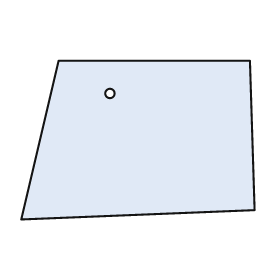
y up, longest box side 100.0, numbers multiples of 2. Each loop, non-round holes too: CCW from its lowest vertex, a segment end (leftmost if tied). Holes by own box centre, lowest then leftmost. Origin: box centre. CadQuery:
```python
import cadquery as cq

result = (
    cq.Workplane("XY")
    .moveTo(-50.0, -34.0)
    .lineTo(50.0, -30.0)
    .lineTo(48.0, 34.0)
    .lineTo(-34.0, 34.0)
    .close()
    .moveTo(-12.0, 20.0)
    .circle(2.0)
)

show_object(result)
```